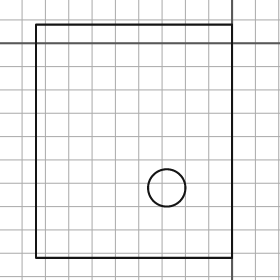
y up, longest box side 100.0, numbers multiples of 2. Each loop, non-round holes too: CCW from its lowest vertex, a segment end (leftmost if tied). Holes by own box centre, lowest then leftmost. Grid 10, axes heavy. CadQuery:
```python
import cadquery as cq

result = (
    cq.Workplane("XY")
    .moveTo(-84.0, -92.0)
    .lineTo(0.0, -92.0)
    .lineTo(0.0, 8.0)
    .lineTo(-84.0, 8.0)
    .close()
    .moveTo(-28.0, -62.0)
    .circle(8.0)
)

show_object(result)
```